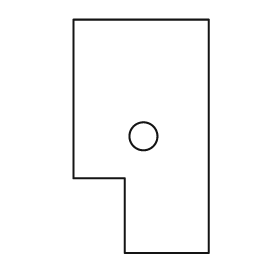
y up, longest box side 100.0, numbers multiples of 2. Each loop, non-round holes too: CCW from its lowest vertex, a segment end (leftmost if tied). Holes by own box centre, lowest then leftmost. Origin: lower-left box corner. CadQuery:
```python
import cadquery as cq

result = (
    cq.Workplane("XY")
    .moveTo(22.0, 0.0)
    .lineTo(58.0, 0.0)
    .lineTo(58.0, 100.0)
    .lineTo(0.0, 100.0)
    .lineTo(0.0, 32.0)
    .lineTo(22.0, 32.0)
    .close()
    .moveTo(30.0, 50.0)
    .circle(6.0)
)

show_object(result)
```